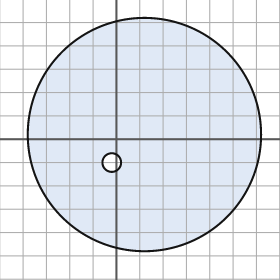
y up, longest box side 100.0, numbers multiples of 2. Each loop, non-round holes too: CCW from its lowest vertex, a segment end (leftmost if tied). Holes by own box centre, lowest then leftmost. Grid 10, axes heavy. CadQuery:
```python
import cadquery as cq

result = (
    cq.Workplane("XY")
    .moveTo(12.0, 2.0)
    .circle(50.0)
    .moveTo(-2.0, -10.0)
    .circle(4.0)
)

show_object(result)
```